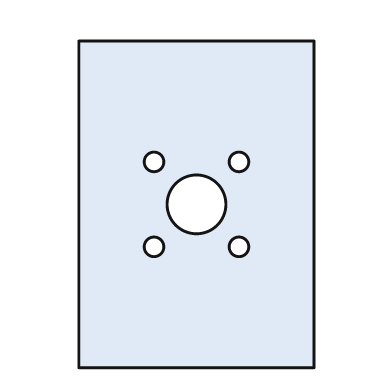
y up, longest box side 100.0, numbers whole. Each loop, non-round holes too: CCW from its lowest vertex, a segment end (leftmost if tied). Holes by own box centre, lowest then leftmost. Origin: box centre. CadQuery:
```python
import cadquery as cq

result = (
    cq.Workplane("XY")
    .moveTo(-36.0, -50.0)
    .lineTo(36.0, -50.0)
    .lineTo(36.0, 50.0)
    .lineTo(-36.0, 50.0)
    .close()
    .moveTo(-13.0, -13.0)
    .circle(3.0)
    .moveTo(13.0, -13.0)
    .circle(3.0)
    .moveTo(0.0, 0.0)
    .circle(9.0)
    .moveTo(-13.0, 13.0)
    .circle(3.0)
    .moveTo(13.0, 13.0)
    .circle(3.0)
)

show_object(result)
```